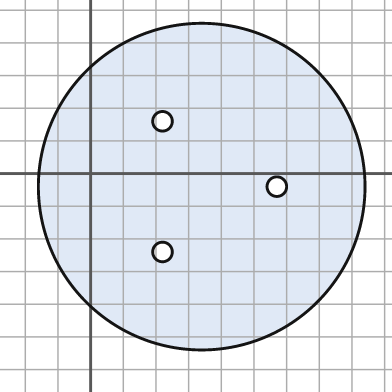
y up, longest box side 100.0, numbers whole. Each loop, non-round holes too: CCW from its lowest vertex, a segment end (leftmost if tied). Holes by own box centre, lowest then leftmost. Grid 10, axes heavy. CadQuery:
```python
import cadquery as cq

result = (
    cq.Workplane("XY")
    .moveTo(34.0, -4.0)
    .circle(50.0)
    .moveTo(22.0, -24.0)
    .circle(3.0)
    .moveTo(57.0, -4.0)
    .circle(3.0)
    .moveTo(22.0, 16.0)
    .circle(3.0)
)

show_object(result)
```